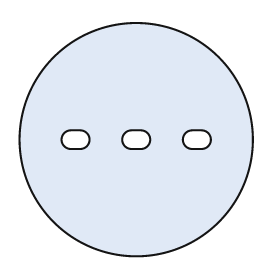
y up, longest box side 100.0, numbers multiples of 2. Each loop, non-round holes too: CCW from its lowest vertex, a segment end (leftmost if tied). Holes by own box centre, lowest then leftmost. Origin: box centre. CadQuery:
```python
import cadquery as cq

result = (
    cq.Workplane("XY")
    .moveTo(0.0, 0.0)
    .circle(50.0)
    .moveTo(-28.0, -4.0)
    .lineTo(-24.0, -4.0)
    .threePointArc((-20.0, 0.0), (-24.0, 4.0))
    .lineTo(-28.0, 4.0)
    .threePointArc((-32.0, 0.0), (-28.0, -4.0))
    .close()
    .moveTo(-2.0, -4.0)
    .lineTo(2.0, -4.0)
    .threePointArc((6.0, 0.0), (2.0, 4.0))
    .lineTo(-2.0, 4.0)
    .threePointArc((-6.0, 0.0), (-2.0, -4.0))
    .close()
    .moveTo(24.0, -4.0)
    .lineTo(28.0, -4.0)
    .threePointArc((32.0, 0.0), (28.0, 4.0))
    .lineTo(24.0, 4.0)
    .threePointArc((20.0, 0.0), (24.0, -4.0))
    .close()
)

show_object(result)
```